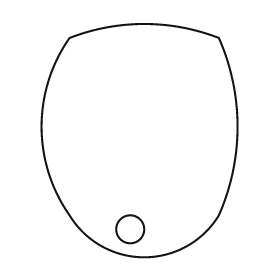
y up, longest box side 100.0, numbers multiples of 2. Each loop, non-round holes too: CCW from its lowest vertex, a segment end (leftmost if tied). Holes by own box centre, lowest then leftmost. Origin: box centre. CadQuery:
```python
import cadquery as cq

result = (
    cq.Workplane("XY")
    .moveTo(-30.0, -32.0)
    .threePointArc((2.0, -50.0), (34.0, -32.0))
    .threePointArc((42.0, 6.0), (34.0, 44.0))
    .threePointArc((2.0, 50.0), (-30.0, 44.0))
    .threePointArc((-42.0, 6.0), (-30.0, -32.0))
    .close()
    .moveTo(-4.0, -38.0)
    .circle(6.0)
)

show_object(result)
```